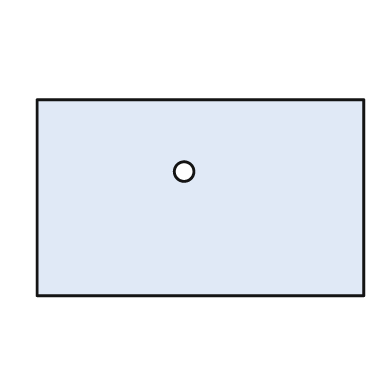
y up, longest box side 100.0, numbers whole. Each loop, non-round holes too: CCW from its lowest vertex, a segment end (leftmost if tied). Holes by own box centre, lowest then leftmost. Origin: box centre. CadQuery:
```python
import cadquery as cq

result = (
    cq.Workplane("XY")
    .moveTo(-50.0, -30.0)
    .lineTo(50.0, -30.0)
    .lineTo(50.0, 30.0)
    .lineTo(-50.0, 30.0)
    .close()
    .moveTo(-5.0, 8.0)
    .circle(3.0)
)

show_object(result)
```